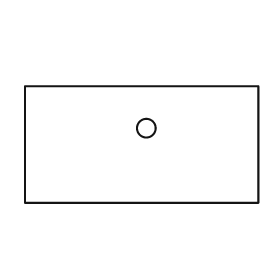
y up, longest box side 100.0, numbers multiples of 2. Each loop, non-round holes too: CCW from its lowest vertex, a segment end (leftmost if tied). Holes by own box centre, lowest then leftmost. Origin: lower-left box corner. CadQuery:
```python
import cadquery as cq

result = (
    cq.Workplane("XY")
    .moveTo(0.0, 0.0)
    .lineTo(100.0, 0.0)
    .lineTo(100.0, 50.0)
    .lineTo(0.0, 50.0)
    .close()
    .moveTo(52.0, 32.0)
    .circle(4.0)
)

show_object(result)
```